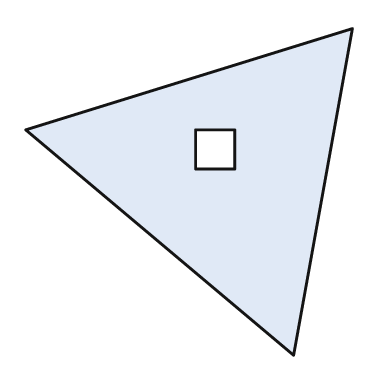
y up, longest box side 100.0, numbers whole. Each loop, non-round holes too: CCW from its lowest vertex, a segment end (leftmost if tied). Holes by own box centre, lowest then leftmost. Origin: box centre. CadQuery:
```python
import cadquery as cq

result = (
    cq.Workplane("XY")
    .moveTo(32.0, -50.0)
    .lineTo(50.0, 50.0)
    .lineTo(-50.0, 19.0)
    .close()
    .moveTo(2.0, 7.0)
    .lineTo(14.0, 7.0)
    .lineTo(14.0, 19.0)
    .lineTo(2.0, 19.0)
    .close()
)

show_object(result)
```